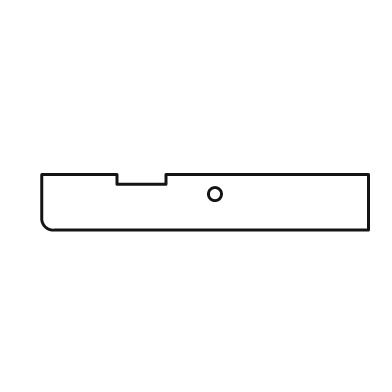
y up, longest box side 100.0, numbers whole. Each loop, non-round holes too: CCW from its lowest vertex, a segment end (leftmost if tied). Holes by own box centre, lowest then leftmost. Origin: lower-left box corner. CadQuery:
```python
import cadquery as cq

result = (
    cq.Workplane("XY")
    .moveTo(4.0, 0.0)
    .lineTo(100.0, 0.0)
    .lineTo(100.0, 17.0)
    .lineTo(38.0, 17.0)
    .lineTo(38.0, 14.0)
    .lineTo(23.0, 14.0)
    .lineTo(23.0, 17.0)
    .lineTo(0.0, 17.0)
    .lineTo(0.0, 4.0)
    .threePointArc((1.0, 1.0), (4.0, 0.0))
    .close()
    .moveTo(53.0, 11.0)
    .circle(2.0)
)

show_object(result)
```